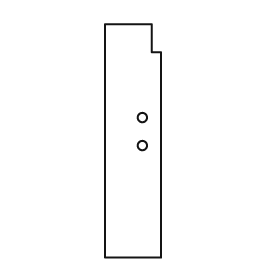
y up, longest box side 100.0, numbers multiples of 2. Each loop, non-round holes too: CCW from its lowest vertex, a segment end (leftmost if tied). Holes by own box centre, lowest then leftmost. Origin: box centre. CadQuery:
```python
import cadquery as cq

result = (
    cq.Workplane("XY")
    .moveTo(-12.0, -50.0)
    .lineTo(12.0, -50.0)
    .lineTo(12.0, 38.0)
    .lineTo(8.0, 38.0)
    .lineTo(8.0, 50.0)
    .lineTo(-12.0, 50.0)
    .close()
    .moveTo(4.0, -2.0)
    .circle(2.0)
    .moveTo(4.0, 10.0)
    .circle(2.0)
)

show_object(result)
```